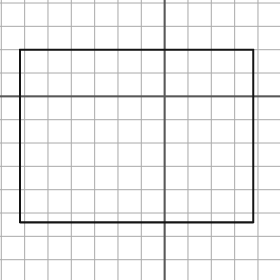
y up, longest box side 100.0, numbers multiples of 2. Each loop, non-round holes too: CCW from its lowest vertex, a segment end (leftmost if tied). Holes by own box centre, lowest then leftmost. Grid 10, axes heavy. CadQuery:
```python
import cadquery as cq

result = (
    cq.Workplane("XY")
    .moveTo(-62.0, -54.0)
    .lineTo(38.0, -54.0)
    .lineTo(38.0, 20.0)
    .lineTo(-62.0, 20.0)
    .close()
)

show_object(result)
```